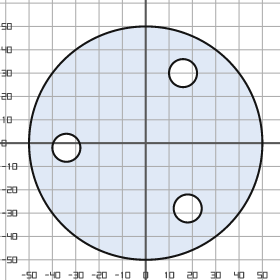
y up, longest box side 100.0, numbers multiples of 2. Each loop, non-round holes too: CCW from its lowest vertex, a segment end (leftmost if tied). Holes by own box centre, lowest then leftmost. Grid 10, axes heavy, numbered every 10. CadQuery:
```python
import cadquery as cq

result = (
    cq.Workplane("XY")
    .moveTo(0.0, 0.0)
    .circle(50.0)
    .moveTo(18.0, -28.0)
    .circle(6.0)
    .moveTo(-34.0, -2.0)
    .circle(6.0)
    .moveTo(16.0, 30.0)
    .circle(6.0)
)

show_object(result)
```